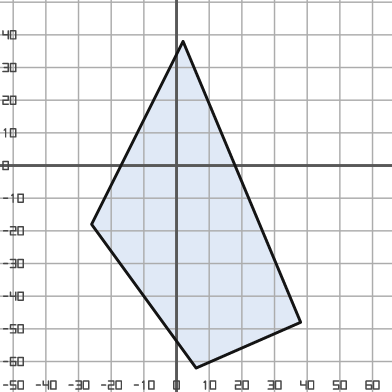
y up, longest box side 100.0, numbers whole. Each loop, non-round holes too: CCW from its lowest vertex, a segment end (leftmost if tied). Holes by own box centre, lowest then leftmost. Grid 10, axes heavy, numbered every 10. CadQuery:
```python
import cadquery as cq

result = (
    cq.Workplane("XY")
    .moveTo(6.0, -62.0)
    .lineTo(38.0, -48.0)
    .lineTo(2.0, 38.0)
    .lineTo(-26.0, -18.0)
    .close()
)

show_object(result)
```